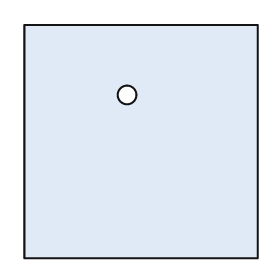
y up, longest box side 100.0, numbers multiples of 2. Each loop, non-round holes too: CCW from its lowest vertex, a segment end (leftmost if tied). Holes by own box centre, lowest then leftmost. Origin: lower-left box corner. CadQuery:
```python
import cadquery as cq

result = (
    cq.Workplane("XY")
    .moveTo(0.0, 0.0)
    .lineTo(100.0, 0.0)
    .lineTo(100.0, 100.0)
    .lineTo(0.0, 100.0)
    .close()
    .moveTo(44.0, 70.0)
    .circle(4.0)
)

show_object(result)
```